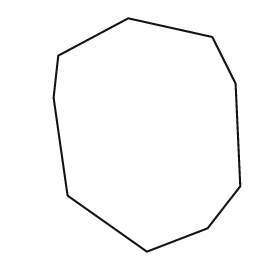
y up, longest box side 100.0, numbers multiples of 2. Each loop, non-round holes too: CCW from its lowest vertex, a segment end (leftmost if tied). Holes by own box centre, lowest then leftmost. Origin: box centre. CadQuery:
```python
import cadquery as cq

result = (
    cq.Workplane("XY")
    .moveTo(0.0, -50.0)
    .lineTo(26.0, -40.0)
    .lineTo(40.0, -22.0)
    .lineTo(38.0, 22.0)
    .lineTo(28.0, 42.0)
    .lineTo(-8.0, 50.0)
    .lineTo(-38.0, 34.0)
    .lineTo(-40.0, 16.0)
    .lineTo(-34.0, -26.0)
    .close()
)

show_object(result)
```